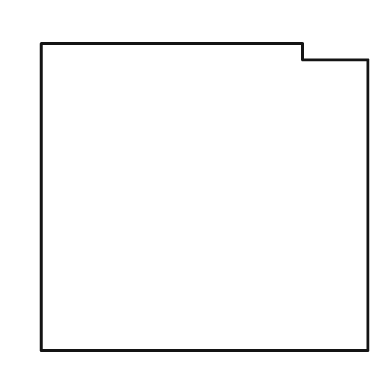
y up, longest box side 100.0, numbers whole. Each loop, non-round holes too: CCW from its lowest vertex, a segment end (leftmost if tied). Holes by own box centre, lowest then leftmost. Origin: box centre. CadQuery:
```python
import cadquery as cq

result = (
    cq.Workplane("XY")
    .moveTo(-50.0, -47.0)
    .lineTo(50.0, -47.0)
    .lineTo(50.0, 42.0)
    .lineTo(30.0, 42.0)
    .lineTo(30.0, 47.0)
    .lineTo(-50.0, 47.0)
    .close()
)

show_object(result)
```